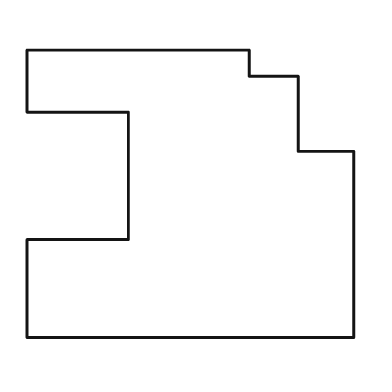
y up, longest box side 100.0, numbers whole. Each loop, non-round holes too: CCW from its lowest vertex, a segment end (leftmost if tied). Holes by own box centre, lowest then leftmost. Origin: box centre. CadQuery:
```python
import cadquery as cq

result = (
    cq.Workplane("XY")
    .moveTo(-50.0, -44.0)
    .lineTo(50.0, -44.0)
    .lineTo(50.0, 13.0)
    .lineTo(33.0, 13.0)
    .lineTo(33.0, 36.0)
    .lineTo(18.0, 36.0)
    .lineTo(18.0, 44.0)
    .lineTo(-50.0, 44.0)
    .lineTo(-50.0, 25.0)
    .lineTo(-19.0, 25.0)
    .lineTo(-19.0, -14.0)
    .lineTo(-50.0, -14.0)
    .close()
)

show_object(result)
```